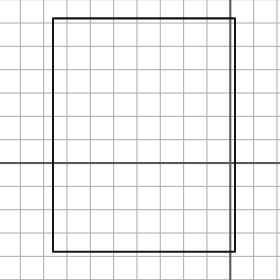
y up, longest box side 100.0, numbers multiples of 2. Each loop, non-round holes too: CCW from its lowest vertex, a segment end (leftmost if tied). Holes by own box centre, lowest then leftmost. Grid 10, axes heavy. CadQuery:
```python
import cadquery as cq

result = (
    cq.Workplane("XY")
    .moveTo(-76.0, -38.0)
    .lineTo(2.0, -38.0)
    .lineTo(2.0, 62.0)
    .lineTo(-76.0, 62.0)
    .close()
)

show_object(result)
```